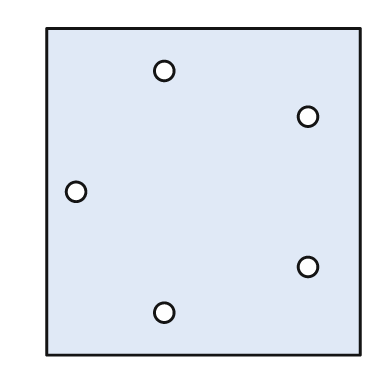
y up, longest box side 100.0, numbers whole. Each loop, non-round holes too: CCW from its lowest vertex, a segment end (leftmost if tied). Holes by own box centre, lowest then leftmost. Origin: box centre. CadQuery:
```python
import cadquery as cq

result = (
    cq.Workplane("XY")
    .moveTo(-48.0, -50.0)
    .lineTo(48.0, -50.0)
    .lineTo(48.0, 50.0)
    .lineTo(-48.0, 50.0)
    .close()
    .moveTo(-12.0, -37.0)
    .circle(3.0)
    .moveTo(32.0, -23.0)
    .circle(3.0)
    .moveTo(-39.0, 0.0)
    .circle(3.0)
    .moveTo(32.0, 23.0)
    .circle(3.0)
    .moveTo(-12.0, 37.0)
    .circle(3.0)
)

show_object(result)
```